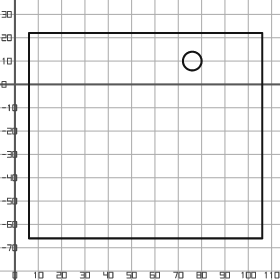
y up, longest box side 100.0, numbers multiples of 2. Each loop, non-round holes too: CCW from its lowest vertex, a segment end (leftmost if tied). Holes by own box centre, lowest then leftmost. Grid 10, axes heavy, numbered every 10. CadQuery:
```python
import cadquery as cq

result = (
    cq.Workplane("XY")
    .moveTo(6.0, -66.0)
    .lineTo(106.0, -66.0)
    .lineTo(106.0, 22.0)
    .lineTo(6.0, 22.0)
    .close()
    .moveTo(76.0, 10.0)
    .circle(4.0)
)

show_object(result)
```